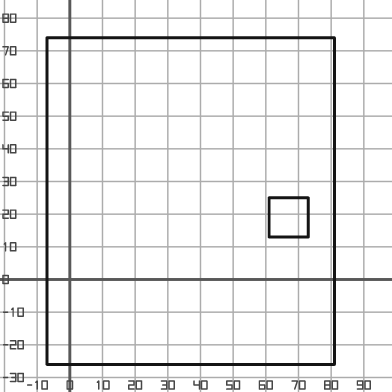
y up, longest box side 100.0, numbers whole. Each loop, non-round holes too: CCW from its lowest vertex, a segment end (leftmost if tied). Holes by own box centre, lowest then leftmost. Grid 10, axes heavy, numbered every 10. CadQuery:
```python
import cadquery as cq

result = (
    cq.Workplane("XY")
    .moveTo(-7.0, -26.0)
    .lineTo(81.0, -26.0)
    .lineTo(81.0, 74.0)
    .lineTo(-7.0, 74.0)
    .close()
    .moveTo(61.0, 13.0)
    .lineTo(73.0, 13.0)
    .lineTo(73.0, 25.0)
    .lineTo(61.0, 25.0)
    .close()
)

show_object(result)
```